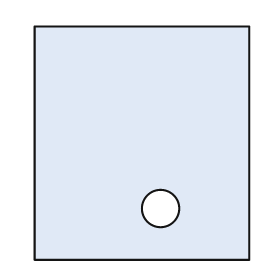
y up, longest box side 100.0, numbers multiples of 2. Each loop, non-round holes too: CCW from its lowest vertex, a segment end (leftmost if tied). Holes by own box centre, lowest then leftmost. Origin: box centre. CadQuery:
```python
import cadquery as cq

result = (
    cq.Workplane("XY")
    .moveTo(-46.0, -50.0)
    .lineTo(46.0, -50.0)
    .lineTo(46.0, 50.0)
    .lineTo(-46.0, 50.0)
    .close()
    .moveTo(8.0, -28.0)
    .circle(8.0)
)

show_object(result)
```